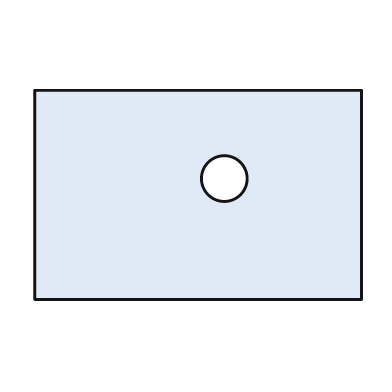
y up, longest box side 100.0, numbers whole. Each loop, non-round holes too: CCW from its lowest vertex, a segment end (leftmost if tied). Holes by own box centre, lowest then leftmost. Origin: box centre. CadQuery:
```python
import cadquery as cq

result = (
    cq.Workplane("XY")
    .moveTo(-50.0, -32.0)
    .lineTo(50.0, -32.0)
    .lineTo(50.0, 32.0)
    .lineTo(-50.0, 32.0)
    .close()
    .moveTo(8.0, 5.0)
    .circle(7.0)
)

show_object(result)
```